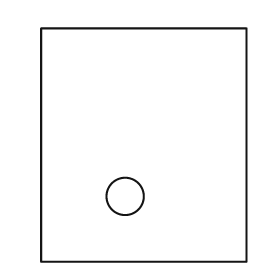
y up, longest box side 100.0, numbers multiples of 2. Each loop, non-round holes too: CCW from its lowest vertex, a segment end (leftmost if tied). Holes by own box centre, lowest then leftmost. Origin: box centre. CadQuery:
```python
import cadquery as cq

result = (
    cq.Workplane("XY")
    .moveTo(-44.0, -50.0)
    .lineTo(44.0, -50.0)
    .lineTo(44.0, 50.0)
    .lineTo(-44.0, 50.0)
    .close()
    .moveTo(-8.0, -22.0)
    .circle(8.0)
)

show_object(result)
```